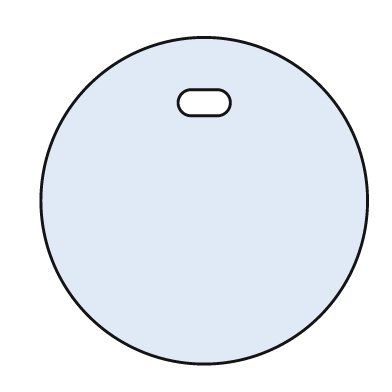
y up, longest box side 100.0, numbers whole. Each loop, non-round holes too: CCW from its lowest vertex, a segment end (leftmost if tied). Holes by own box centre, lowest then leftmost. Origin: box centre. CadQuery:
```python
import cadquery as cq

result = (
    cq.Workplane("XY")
    .moveTo(0.0, 0.0)
    .circle(50.0)
    .moveTo(-4.0, 26.0)
    .lineTo(4.0, 26.0)
    .threePointArc((8.0, 30.0), (4.0, 34.0))
    .lineTo(-4.0, 34.0)
    .threePointArc((-8.0, 30.0), (-4.0, 26.0))
    .close()
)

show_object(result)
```